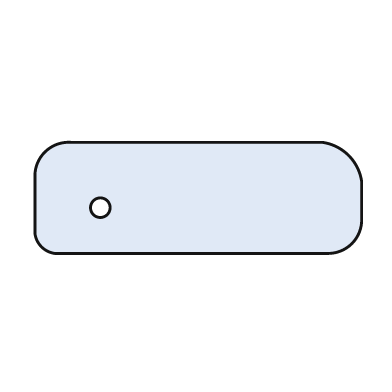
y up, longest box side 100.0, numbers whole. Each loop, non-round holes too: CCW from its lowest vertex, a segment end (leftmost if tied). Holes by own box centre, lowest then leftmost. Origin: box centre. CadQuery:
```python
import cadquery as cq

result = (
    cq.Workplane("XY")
    .moveTo(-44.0, -17.0)
    .lineTo(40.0, -17.0)
    .threePointArc((47.0, -14.0), (50.0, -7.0))
    .lineTo(50.0, 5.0)
    .threePointArc((46.0, 13.0), (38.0, 17.0))
    .lineTo(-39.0, 17.0)
    .threePointArc((-47.0, 14.0), (-50.0, 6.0))
    .lineTo(-50.0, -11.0)
    .threePointArc((-48.0, -15.0), (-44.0, -17.0))
    .close()
    .moveTo(-30.0, -3.0)
    .circle(3.0)
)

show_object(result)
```